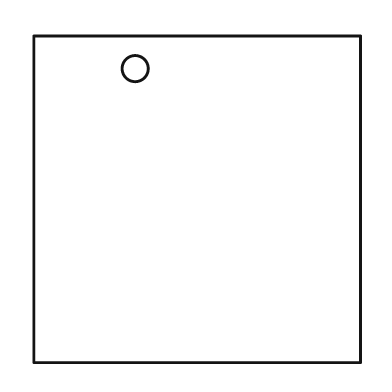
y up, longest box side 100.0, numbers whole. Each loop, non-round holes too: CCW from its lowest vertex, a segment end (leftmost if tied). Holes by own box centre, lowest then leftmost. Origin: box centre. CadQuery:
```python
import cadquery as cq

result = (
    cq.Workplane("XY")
    .moveTo(-50.0, -50.0)
    .lineTo(50.0, -50.0)
    .lineTo(50.0, 50.0)
    .lineTo(-50.0, 50.0)
    .close()
    .moveTo(-19.0, 40.0)
    .circle(4.0)
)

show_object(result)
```